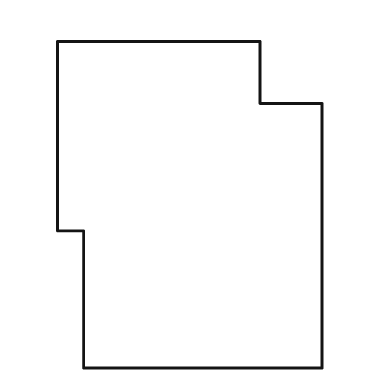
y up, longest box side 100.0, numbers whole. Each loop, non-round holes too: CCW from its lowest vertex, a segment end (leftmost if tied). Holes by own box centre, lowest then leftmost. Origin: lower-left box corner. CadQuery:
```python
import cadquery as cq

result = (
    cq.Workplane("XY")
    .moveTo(8.0, 0.0)
    .lineTo(81.0, 0.0)
    .lineTo(81.0, 81.0)
    .lineTo(62.0, 81.0)
    .lineTo(62.0, 100.0)
    .lineTo(0.0, 100.0)
    .lineTo(0.0, 42.0)
    .lineTo(8.0, 42.0)
    .close()
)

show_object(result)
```